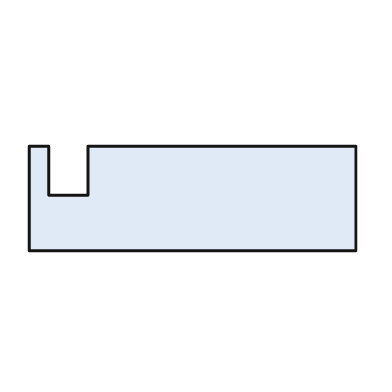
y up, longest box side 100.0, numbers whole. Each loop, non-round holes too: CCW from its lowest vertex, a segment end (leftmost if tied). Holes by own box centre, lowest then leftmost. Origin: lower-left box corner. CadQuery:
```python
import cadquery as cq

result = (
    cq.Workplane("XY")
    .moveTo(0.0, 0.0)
    .lineTo(100.0, 0.0)
    .lineTo(100.0, 32.0)
    .lineTo(18.0, 32.0)
    .lineTo(18.0, 17.0)
    .lineTo(6.0, 17.0)
    .lineTo(6.0, 32.0)
    .lineTo(0.0, 32.0)
    .close()
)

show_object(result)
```